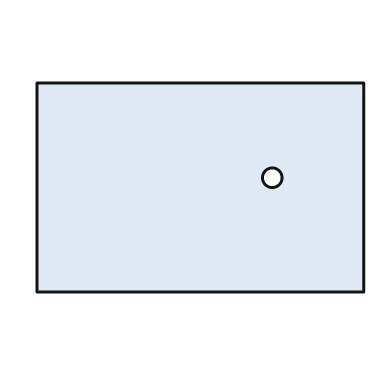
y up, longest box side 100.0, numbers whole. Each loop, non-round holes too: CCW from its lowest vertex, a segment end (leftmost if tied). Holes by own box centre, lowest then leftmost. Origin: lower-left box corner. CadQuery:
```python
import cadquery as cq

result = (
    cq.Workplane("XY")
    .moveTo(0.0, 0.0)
    .lineTo(100.0, 0.0)
    .lineTo(100.0, 64.0)
    .lineTo(0.0, 64.0)
    .close()
    .moveTo(72.0, 35.0)
    .circle(3.0)
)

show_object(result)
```